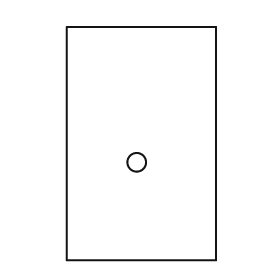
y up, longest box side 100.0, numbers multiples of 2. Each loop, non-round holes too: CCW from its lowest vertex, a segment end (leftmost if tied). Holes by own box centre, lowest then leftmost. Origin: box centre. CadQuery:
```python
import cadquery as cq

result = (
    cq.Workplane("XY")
    .moveTo(-32.0, -50.0)
    .lineTo(32.0, -50.0)
    .lineTo(32.0, 50.0)
    .lineTo(-32.0, 50.0)
    .close()
    .moveTo(-2.0, -8.0)
    .circle(4.0)
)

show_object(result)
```